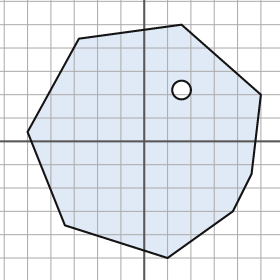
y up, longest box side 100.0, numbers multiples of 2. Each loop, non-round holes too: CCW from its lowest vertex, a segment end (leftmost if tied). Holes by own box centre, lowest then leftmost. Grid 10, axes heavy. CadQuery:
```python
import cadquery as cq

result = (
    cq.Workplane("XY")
    .moveTo(10.0, -50.0)
    .lineTo(38.0, -30.0)
    .lineTo(46.0, -14.0)
    .lineTo(50.0, 20.0)
    .lineTo(16.0, 50.0)
    .lineTo(-28.0, 44.0)
    .lineTo(-50.0, 4.0)
    .lineTo(-34.0, -36.0)
    .close()
    .moveTo(16.0, 22.0)
    .circle(4.0)
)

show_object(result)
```